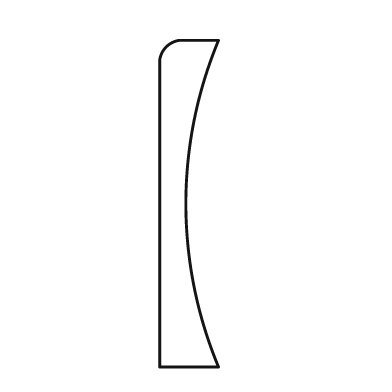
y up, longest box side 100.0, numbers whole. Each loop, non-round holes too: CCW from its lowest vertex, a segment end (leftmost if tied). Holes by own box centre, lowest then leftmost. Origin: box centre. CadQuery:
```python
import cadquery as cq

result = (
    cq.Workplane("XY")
    .moveTo(-9.0, -50.0)
    .lineTo(9.0, -50.0)
    .threePointArc((-1.0, 0.0), (9.0, 50.0))
    .lineTo(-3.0, 50.0)
    .threePointArc((-7.0, 48.0), (-9.0, 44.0))
    .close()
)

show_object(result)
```